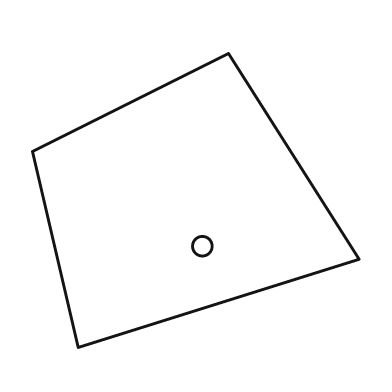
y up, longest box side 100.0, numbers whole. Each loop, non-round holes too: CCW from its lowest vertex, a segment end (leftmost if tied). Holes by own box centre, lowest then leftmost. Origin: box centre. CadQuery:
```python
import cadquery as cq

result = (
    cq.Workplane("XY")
    .moveTo(-36.0, -45.0)
    .lineTo(50.0, -18.0)
    .lineTo(10.0, 45.0)
    .lineTo(-50.0, 15.0)
    .close()
    .moveTo(2.0, -14.0)
    .circle(3.0)
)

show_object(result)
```